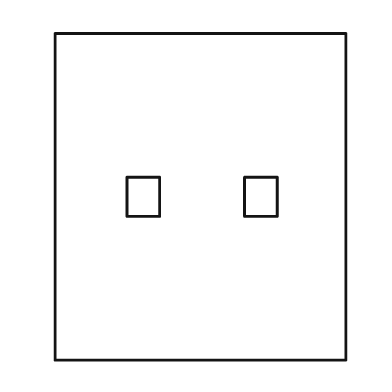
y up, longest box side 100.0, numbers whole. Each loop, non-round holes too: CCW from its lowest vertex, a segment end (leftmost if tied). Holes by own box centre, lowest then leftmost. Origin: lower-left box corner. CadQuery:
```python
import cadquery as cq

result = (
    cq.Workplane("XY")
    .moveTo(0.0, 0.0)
    .lineTo(89.0, 0.0)
    .lineTo(89.0, 100.0)
    .lineTo(0.0, 100.0)
    .close()
    .moveTo(22.0, 44.0)
    .lineTo(32.0, 44.0)
    .lineTo(32.0, 56.0)
    .lineTo(22.0, 56.0)
    .close()
    .moveTo(58.0, 44.0)
    .lineTo(68.0, 44.0)
    .lineTo(68.0, 56.0)
    .lineTo(58.0, 56.0)
    .close()
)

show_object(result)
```